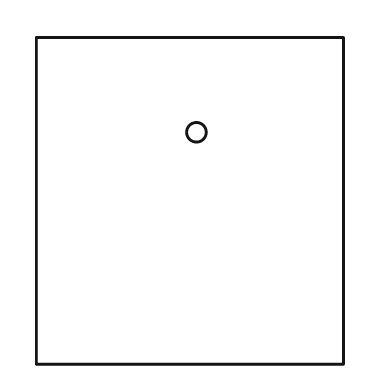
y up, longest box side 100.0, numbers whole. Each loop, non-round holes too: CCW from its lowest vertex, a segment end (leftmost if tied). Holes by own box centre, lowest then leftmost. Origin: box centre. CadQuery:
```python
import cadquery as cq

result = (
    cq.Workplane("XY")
    .moveTo(-47.0, -50.0)
    .lineTo(47.0, -50.0)
    .lineTo(47.0, 50.0)
    .lineTo(-47.0, 50.0)
    .close()
    .moveTo(2.0, 21.0)
    .circle(3.0)
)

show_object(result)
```